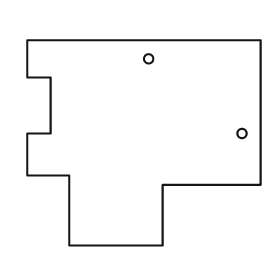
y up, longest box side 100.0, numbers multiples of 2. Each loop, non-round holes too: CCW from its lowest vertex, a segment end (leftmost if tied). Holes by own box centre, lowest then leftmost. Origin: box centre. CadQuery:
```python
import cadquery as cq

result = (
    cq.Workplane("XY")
    .moveTo(-32.0, -44.0)
    .lineTo(8.0, -44.0)
    .lineTo(8.0, -18.0)
    .lineTo(50.0, -18.0)
    .lineTo(50.0, 44.0)
    .lineTo(-50.0, 44.0)
    .lineTo(-50.0, 28.0)
    .lineTo(-40.0, 28.0)
    .lineTo(-40.0, 4.0)
    .lineTo(-50.0, 4.0)
    .lineTo(-50.0, -14.0)
    .lineTo(-32.0, -14.0)
    .close()
    .moveTo(42.0, 4.0)
    .circle(2.0)
    .moveTo(2.0, 36.0)
    .circle(2.0)
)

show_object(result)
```